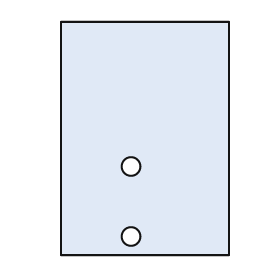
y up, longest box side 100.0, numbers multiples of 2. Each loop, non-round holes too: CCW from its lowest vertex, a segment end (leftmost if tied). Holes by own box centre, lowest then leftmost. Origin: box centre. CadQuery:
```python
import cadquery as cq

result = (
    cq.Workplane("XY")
    .moveTo(-36.0, -50.0)
    .lineTo(36.0, -50.0)
    .lineTo(36.0, 50.0)
    .lineTo(-36.0, 50.0)
    .close()
    .moveTo(-6.0, -42.0)
    .circle(4.0)
    .moveTo(-6.0, -12.0)
    .circle(4.0)
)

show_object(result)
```